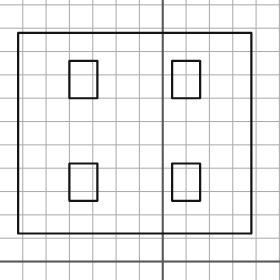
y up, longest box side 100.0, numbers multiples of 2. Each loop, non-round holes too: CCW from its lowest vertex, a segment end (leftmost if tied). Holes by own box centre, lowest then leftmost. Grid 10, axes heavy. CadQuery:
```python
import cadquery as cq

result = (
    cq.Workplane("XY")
    .moveTo(-62.0, 12.0)
    .lineTo(38.0, 12.0)
    .lineTo(38.0, 98.0)
    .lineTo(-62.0, 98.0)
    .close()
    .moveTo(-40.0, 26.0)
    .lineTo(-28.0, 26.0)
    .lineTo(-28.0, 42.0)
    .lineTo(-40.0, 42.0)
    .close()
    .moveTo(4.0, 26.0)
    .lineTo(16.0, 26.0)
    .lineTo(16.0, 42.0)
    .lineTo(4.0, 42.0)
    .close()
    .moveTo(-40.0, 70.0)
    .lineTo(-28.0, 70.0)
    .lineTo(-28.0, 86.0)
    .lineTo(-40.0, 86.0)
    .close()
    .moveTo(4.0, 70.0)
    .lineTo(16.0, 70.0)
    .lineTo(16.0, 86.0)
    .lineTo(4.0, 86.0)
    .close()
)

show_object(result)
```